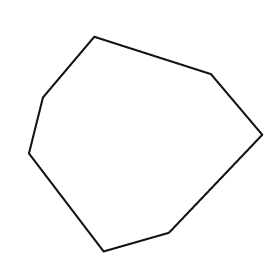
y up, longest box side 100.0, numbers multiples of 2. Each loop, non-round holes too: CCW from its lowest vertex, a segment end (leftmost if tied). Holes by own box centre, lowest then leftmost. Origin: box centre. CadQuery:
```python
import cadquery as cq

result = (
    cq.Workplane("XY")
    .moveTo(-18.0, -46.0)
    .lineTo(10.0, -38.0)
    .lineTo(50.0, 4.0)
    .lineTo(28.0, 30.0)
    .lineTo(-22.0, 46.0)
    .lineTo(-44.0, 20.0)
    .lineTo(-50.0, -4.0)
    .close()
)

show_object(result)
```